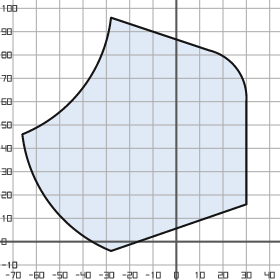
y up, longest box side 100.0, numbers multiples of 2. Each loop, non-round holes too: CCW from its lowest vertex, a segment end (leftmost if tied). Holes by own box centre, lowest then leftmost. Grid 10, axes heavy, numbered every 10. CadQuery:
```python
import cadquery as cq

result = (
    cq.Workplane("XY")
    .moveTo(-28.0, -4.0)
    .lineTo(30.0, 16.0)
    .lineTo(30.0, 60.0)
    .threePointArc((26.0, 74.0), (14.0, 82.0))
    .lineTo(-28.0, 96.0)
    .threePointArc((-40.0, 66.0), (-66.0, 46.0))
    .threePointArc((-54.0, 16.0), (-28.0, -4.0))
    .close()
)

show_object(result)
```